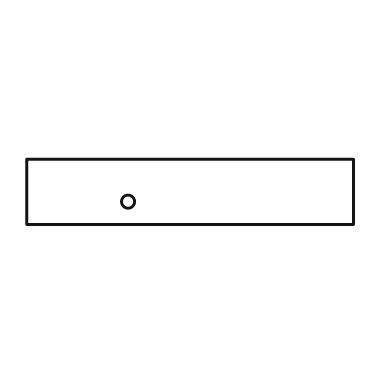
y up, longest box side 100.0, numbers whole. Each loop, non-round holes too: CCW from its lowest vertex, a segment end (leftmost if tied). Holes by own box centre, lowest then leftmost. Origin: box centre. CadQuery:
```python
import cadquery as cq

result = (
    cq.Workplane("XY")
    .moveTo(-50.0, -10.0)
    .lineTo(50.0, -10.0)
    .lineTo(50.0, 10.0)
    .lineTo(-50.0, 10.0)
    .close()
    .moveTo(-19.0, -3.0)
    .circle(2.0)
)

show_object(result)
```